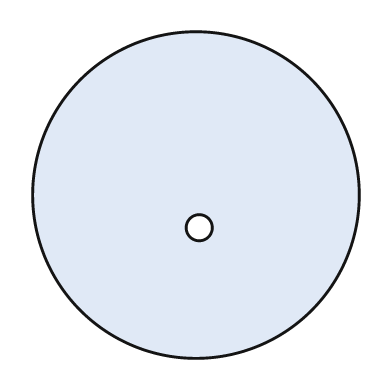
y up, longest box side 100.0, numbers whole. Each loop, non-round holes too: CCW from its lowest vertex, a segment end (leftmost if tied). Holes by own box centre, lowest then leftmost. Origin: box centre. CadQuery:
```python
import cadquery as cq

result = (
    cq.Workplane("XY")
    .moveTo(0.0, 0.0)
    .circle(50.0)
    .moveTo(1.0, -10.0)
    .circle(4.0)
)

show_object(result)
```